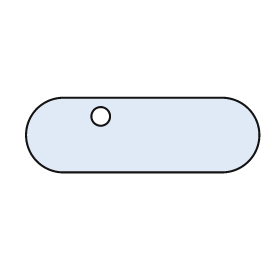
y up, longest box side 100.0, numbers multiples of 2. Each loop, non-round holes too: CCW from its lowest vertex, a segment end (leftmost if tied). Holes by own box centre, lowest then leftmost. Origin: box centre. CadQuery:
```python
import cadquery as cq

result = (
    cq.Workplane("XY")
    .moveTo(-34.0, -16.0)
    .lineTo(34.0, -16.0)
    .threePointArc((50.0, 0.0), (34.0, 16.0))
    .lineTo(-34.0, 16.0)
    .threePointArc((-50.0, 0.0), (-34.0, -16.0))
    .close()
    .moveTo(-18.0, 8.0)
    .circle(4.0)
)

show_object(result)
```